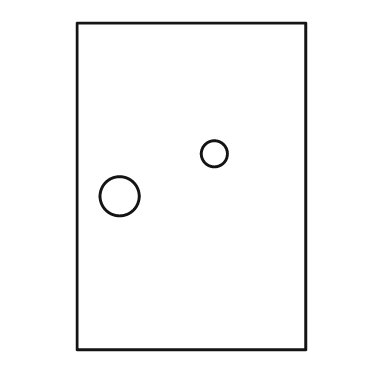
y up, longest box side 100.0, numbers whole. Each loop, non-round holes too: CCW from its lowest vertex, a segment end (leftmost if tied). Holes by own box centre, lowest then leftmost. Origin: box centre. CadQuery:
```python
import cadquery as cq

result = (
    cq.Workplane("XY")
    .moveTo(-35.0, -50.0)
    .lineTo(35.0, -50.0)
    .lineTo(35.0, 50.0)
    .lineTo(-35.0, 50.0)
    .close()
    .moveTo(-22.0, -3.0)
    .circle(6.0)
    .moveTo(7.0, 10.0)
    .circle(4.0)
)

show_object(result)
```